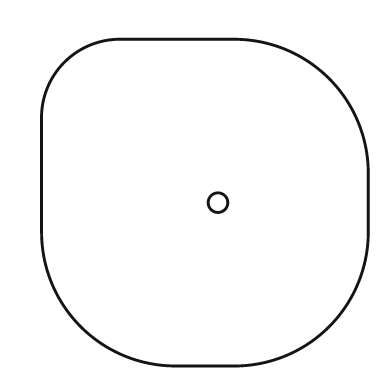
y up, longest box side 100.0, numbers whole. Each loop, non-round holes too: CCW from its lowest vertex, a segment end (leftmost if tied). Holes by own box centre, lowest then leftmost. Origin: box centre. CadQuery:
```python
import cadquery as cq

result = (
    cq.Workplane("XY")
    .moveTo(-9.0, -50.0)
    .lineTo(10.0, -50.0)
    .threePointArc((38.0, -38.0), (50.0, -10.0))
    .lineTo(50.0, 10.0)
    .threePointArc((38.0, 38.0), (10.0, 50.0))
    .lineTo(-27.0, 50.0)
    .threePointArc((-43.0, 43.0), (-50.0, 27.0))
    .lineTo(-50.0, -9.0)
    .threePointArc((-38.0, -38.0), (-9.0, -50.0))
    .close()
    .moveTo(4.0, 0.0)
    .circle(3.0)
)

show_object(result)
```